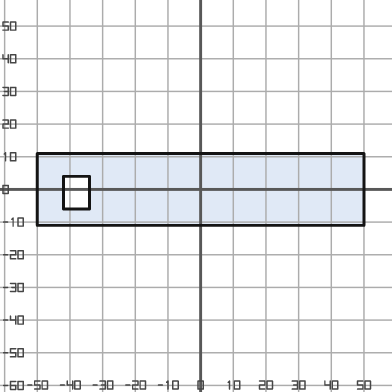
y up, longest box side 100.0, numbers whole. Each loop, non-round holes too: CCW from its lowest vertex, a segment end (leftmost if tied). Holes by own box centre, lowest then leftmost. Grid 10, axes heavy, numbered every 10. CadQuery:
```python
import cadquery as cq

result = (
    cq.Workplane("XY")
    .moveTo(-50.0, -11.0)
    .lineTo(50.0, -11.0)
    .lineTo(50.0, 11.0)
    .lineTo(-50.0, 11.0)
    .close()
    .moveTo(-42.0, -6.0)
    .lineTo(-34.0, -6.0)
    .lineTo(-34.0, 4.0)
    .lineTo(-42.0, 4.0)
    .close()
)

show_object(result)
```